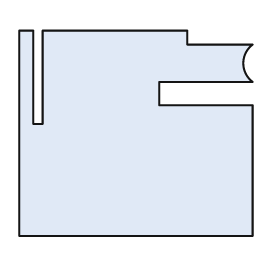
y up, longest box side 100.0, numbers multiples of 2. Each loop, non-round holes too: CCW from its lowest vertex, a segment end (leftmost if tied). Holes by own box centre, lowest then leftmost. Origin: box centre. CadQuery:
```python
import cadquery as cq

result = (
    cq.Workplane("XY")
    .moveTo(-50.0, -44.0)
    .lineTo(50.0, -44.0)
    .lineTo(50.0, 12.0)
    .lineTo(10.0, 12.0)
    .lineTo(10.0, 22.0)
    .lineTo(50.0, 22.0)
    .threePointArc((46.0, 30.0), (50.0, 38.0))
    .lineTo(22.0, 38.0)
    .lineTo(22.0, 44.0)
    .lineTo(-40.0, 44.0)
    .lineTo(-40.0, 4.0)
    .lineTo(-44.0, 4.0)
    .lineTo(-44.0, 44.0)
    .lineTo(-50.0, 44.0)
    .close()
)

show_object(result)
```